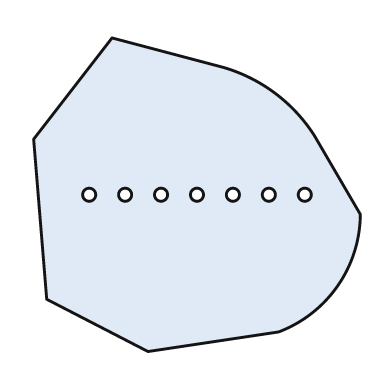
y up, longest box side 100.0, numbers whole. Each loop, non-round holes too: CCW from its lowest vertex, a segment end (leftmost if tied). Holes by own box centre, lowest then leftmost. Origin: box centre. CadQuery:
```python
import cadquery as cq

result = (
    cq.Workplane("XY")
    .moveTo(-15.0, -48.0)
    .lineTo(25.0, -42.0)
    .threePointArc((43.0, -28.0), (50.0, -6.0))
    .lineTo(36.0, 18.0)
    .threePointArc((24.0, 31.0), (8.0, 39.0))
    .lineTo(-26.0, 48.0)
    .lineTo(-50.0, 17.0)
    .lineTo(-46.0, -32.0)
    .close()
    .moveTo(-33.0, 0.0)
    .circle(2.0)
    .moveTo(-22.0, 0.0)
    .circle(2.0)
    .moveTo(-11.0, 0.0)
    .circle(2.0)
    .moveTo(0.0, 0.0)
    .circle(2.0)
    .moveTo(11.0, 0.0)
    .circle(2.0)
    .moveTo(22.0, 0.0)
    .circle(2.0)
    .moveTo(33.0, 0.0)
    .circle(2.0)
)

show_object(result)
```